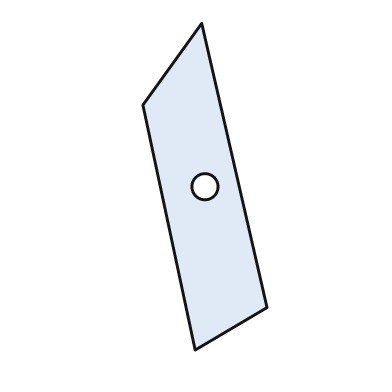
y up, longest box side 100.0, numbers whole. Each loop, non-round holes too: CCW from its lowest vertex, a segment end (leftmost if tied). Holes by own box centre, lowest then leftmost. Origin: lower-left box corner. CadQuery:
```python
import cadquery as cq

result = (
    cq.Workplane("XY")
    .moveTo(16.0, 0.0)
    .lineTo(38.0, 13.0)
    .lineTo(18.0, 100.0)
    .lineTo(0.0, 75.0)
    .close()
    .moveTo(19.0, 50.0)
    .circle(4.0)
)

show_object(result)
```